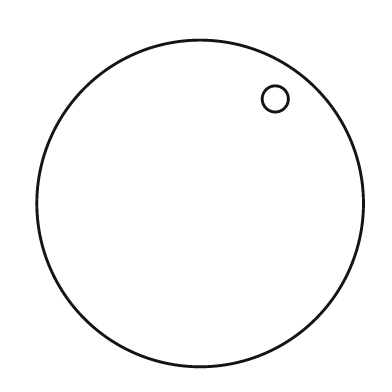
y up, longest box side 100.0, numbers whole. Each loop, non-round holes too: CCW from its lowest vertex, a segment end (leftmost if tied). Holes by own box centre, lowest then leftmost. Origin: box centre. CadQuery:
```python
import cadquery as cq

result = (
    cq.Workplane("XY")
    .moveTo(0.0, 0.0)
    .circle(50.0)
    .moveTo(23.0, 32.0)
    .circle(4.0)
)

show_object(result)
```